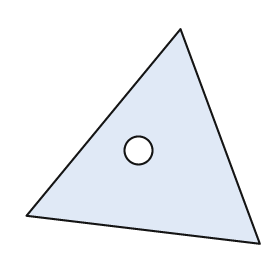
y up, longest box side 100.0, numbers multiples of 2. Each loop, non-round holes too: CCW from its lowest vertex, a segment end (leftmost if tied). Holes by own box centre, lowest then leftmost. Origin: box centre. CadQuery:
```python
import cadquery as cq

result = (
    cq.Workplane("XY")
    .moveTo(50.0, -46.0)
    .lineTo(16.0, 46.0)
    .lineTo(-50.0, -34.0)
    .close()
    .moveTo(-2.0, -6.0)
    .circle(6.0)
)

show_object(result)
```